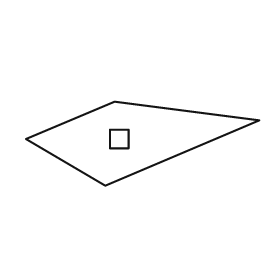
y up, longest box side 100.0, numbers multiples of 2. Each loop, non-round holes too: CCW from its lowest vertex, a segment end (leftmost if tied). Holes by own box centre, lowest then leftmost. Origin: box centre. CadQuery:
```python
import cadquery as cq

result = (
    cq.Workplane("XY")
    .moveTo(-16.0, -18.0)
    .lineTo(50.0, 10.0)
    .lineTo(-12.0, 18.0)
    .lineTo(-50.0, 2.0)
    .close()
    .moveTo(-14.0, -2.0)
    .lineTo(-6.0, -2.0)
    .lineTo(-6.0, 6.0)
    .lineTo(-14.0, 6.0)
    .close()
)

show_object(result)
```